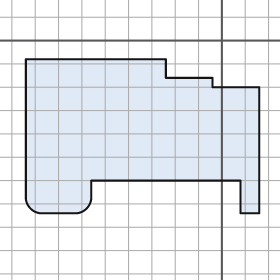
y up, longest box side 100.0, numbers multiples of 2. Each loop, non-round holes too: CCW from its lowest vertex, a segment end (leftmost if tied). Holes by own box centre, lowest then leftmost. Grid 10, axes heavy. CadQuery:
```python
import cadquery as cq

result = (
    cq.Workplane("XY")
    .moveTo(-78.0, -74.0)
    .lineTo(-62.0, -74.0)
    .threePointArc((-58.0, -72.0), (-56.0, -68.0))
    .lineTo(-56.0, -60.0)
    .lineTo(8.0, -60.0)
    .lineTo(8.0, -74.0)
    .lineTo(16.0, -74.0)
    .lineTo(16.0, -20.0)
    .lineTo(-4.0, -20.0)
    .lineTo(-4.0, -16.0)
    .lineTo(-24.0, -16.0)
    .lineTo(-24.0, -8.0)
    .lineTo(-84.0, -8.0)
    .lineTo(-84.0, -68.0)
    .threePointArc((-82.0, -72.0), (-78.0, -74.0))
    .close()
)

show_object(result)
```